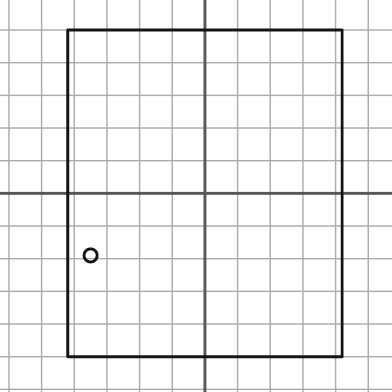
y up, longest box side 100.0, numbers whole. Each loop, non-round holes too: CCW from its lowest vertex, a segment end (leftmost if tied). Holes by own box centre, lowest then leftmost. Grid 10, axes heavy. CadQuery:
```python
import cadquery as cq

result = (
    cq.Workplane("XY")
    .moveTo(-42.0, -50.0)
    .lineTo(42.0, -50.0)
    .lineTo(42.0, 50.0)
    .lineTo(-42.0, 50.0)
    .close()
    .moveTo(-35.0, -19.0)
    .circle(2.0)
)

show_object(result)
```